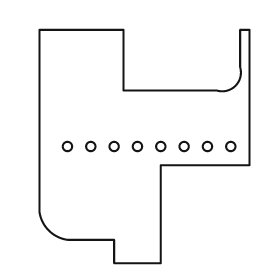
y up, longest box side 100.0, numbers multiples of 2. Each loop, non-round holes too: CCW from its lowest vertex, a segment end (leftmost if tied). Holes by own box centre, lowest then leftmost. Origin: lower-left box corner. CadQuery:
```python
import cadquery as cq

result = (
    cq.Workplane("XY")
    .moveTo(32.0, 0.0)
    .lineTo(52.0, 0.0)
    .lineTo(52.0, 42.0)
    .lineTo(90.0, 42.0)
    .lineTo(90.0, 100.0)
    .lineTo(86.0, 100.0)
    .lineTo(86.0, 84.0)
    .threePointArc((84.0, 76.0), (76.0, 74.0))
    .lineTo(36.0, 74.0)
    .lineTo(36.0, 100.0)
    .lineTo(0.0, 100.0)
    .lineTo(0.0, 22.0)
    .threePointArc((4.0, 14.0), (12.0, 10.0))
    .lineTo(32.0, 10.0)
    .close()
    .moveTo(12.0, 50.0)
    .circle(2.0)
    .moveTo(22.0, 50.0)
    .circle(2.0)
    .moveTo(32.0, 50.0)
    .circle(2.0)
    .moveTo(42.0, 50.0)
    .circle(2.0)
    .moveTo(52.0, 50.0)
    .circle(2.0)
    .moveTo(62.0, 50.0)
    .circle(2.0)
    .moveTo(72.0, 50.0)
    .circle(2.0)
    .moveTo(82.0, 50.0)
    .circle(2.0)
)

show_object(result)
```